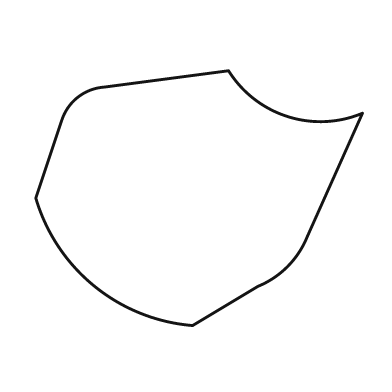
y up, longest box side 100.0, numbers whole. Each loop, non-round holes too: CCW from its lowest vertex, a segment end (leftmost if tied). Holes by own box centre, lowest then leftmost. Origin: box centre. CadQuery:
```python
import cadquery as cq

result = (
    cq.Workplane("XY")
    .moveTo(-2.0, -39.0)
    .lineTo(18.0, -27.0)
    .threePointArc((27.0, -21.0), (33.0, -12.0))
    .lineTo(50.0, 26.0)
    .threePointArc((27.0, 25.0), (9.0, 39.0))
    .lineTo(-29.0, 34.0)
    .threePointArc((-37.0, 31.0), (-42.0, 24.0))
    .lineTo(-50.0, 0.0)
    .threePointArc((-32.0, -27.0), (-2.0, -39.0))
    .close()
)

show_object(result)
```